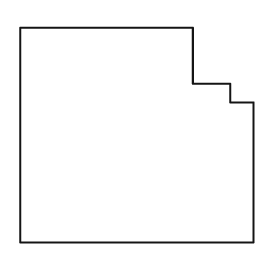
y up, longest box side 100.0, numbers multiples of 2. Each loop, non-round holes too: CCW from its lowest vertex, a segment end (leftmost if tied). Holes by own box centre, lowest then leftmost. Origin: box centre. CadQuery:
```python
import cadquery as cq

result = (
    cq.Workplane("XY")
    .moveTo(-50.0, -46.0)
    .lineTo(50.0, -46.0)
    .lineTo(50.0, 14.0)
    .lineTo(40.0, 14.0)
    .lineTo(40.0, 22.0)
    .lineTo(24.0, 22.0)
    .lineTo(24.0, 46.0)
    .lineTo(-50.0, 46.0)
    .close()
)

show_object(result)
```